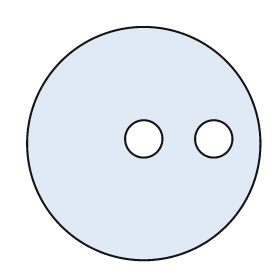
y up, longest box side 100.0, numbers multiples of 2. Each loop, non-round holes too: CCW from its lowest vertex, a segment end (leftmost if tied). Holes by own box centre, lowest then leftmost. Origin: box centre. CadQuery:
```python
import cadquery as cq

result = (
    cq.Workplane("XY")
    .moveTo(0.0, 0.0)
    .circle(50.0)
    .moveTo(0.0, 2.0)
    .circle(8.0)
    .moveTo(30.0, 2.0)
    .circle(8.0)
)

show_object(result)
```